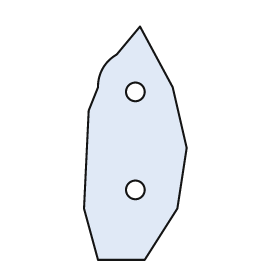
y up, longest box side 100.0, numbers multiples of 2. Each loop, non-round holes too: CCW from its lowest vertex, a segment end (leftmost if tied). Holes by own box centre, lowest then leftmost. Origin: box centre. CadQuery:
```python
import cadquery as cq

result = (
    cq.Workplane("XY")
    .moveTo(-16.0, -50.0)
    .lineTo(4.0, -50.0)
    .lineTo(18.0, -28.0)
    .lineTo(22.0, -2.0)
    .lineTo(16.0, 24.0)
    .lineTo(2.0, 50.0)
    .lineTo(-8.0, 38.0)
    .threePointArc((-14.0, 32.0), (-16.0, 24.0))
    .lineTo(-20.0, 14.0)
    .lineTo(-22.0, -28.0)
    .close()
    .moveTo(0.0, -20.0)
    .circle(4.0)
    .moveTo(0.0, 22.0)
    .circle(4.0)
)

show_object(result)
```